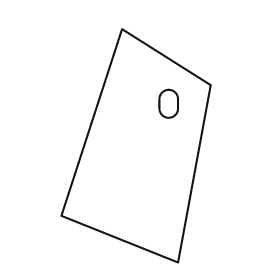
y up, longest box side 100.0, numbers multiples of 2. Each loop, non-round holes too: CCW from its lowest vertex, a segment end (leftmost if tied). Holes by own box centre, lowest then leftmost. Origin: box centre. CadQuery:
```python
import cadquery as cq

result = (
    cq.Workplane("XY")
    .moveTo(18.0, -50.0)
    .lineTo(32.0, 26.0)
    .lineTo(-6.0, 50.0)
    .lineTo(-32.0, -30.0)
    .close()
    .moveTo(10.0, 16.0)
    .threePointArc((14.0, 12.0), (18.0, 16.0))
    .lineTo(18.0, 20.0)
    .threePointArc((14.0, 24.0), (10.0, 20.0))
    .close()
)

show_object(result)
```